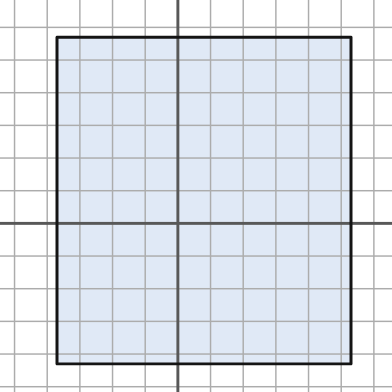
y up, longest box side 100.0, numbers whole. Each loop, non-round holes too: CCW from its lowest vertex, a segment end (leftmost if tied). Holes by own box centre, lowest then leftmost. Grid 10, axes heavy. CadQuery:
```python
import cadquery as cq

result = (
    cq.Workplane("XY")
    .moveTo(-37.0, -43.0)
    .lineTo(53.0, -43.0)
    .lineTo(53.0, 57.0)
    .lineTo(-37.0, 57.0)
    .close()
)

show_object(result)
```